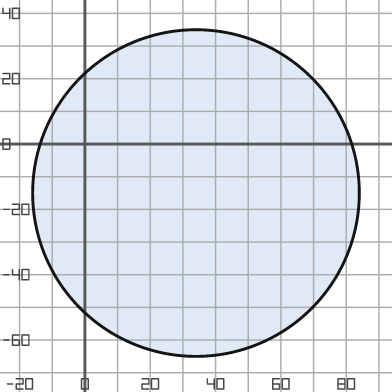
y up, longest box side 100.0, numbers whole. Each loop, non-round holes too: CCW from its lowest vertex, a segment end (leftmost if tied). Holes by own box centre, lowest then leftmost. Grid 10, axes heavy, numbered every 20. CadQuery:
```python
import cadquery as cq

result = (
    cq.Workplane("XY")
    .moveTo(34.0, -15.0)
    .circle(50.0)
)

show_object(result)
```